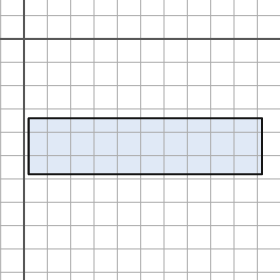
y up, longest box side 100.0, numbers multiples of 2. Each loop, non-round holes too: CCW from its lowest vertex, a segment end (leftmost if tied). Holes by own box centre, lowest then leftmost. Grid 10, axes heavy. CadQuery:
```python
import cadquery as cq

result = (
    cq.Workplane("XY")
    .moveTo(2.0, -58.0)
    .lineTo(102.0, -58.0)
    .lineTo(102.0, -34.0)
    .lineTo(2.0, -34.0)
    .close()
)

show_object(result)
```